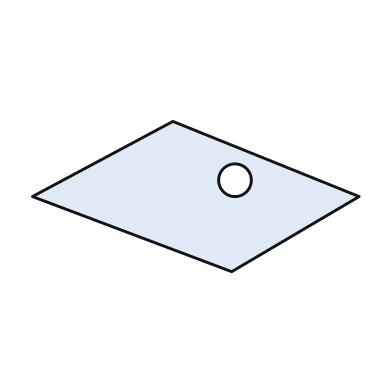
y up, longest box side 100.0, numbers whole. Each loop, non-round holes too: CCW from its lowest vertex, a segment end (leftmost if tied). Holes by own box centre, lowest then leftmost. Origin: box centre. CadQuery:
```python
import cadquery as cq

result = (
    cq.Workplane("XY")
    .moveTo(11.0, -23.0)
    .lineTo(50.0, 0.0)
    .lineTo(-7.0, 23.0)
    .lineTo(-50.0, 0.0)
    .close()
    .moveTo(12.0, 5.0)
    .circle(5.0)
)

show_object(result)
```